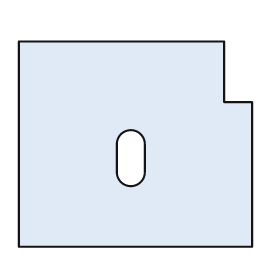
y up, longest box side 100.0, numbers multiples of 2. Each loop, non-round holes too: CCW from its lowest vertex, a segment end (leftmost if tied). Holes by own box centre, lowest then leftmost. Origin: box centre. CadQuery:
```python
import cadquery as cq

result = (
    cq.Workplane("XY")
    .moveTo(-50.0, -44.0)
    .lineTo(50.0, -44.0)
    .lineTo(50.0, 18.0)
    .lineTo(38.0, 18.0)
    .lineTo(38.0, 44.0)
    .lineTo(-50.0, 44.0)
    .close()
    .moveTo(-8.0, -12.0)
    .threePointArc((-2.0, -18.0), (4.0, -12.0))
    .lineTo(4.0, 0.0)
    .threePointArc((-2.0, 6.0), (-8.0, 0.0))
    .close()
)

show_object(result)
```